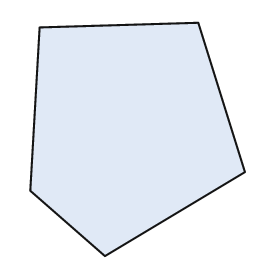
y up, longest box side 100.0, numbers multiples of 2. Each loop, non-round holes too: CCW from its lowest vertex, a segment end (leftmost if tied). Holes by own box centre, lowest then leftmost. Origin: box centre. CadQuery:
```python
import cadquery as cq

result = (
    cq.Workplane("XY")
    .moveTo(-14.0, -50.0)
    .lineTo(46.0, -14.0)
    .lineTo(26.0, 50.0)
    .lineTo(-42.0, 48.0)
    .lineTo(-46.0, -22.0)
    .close()
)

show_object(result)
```